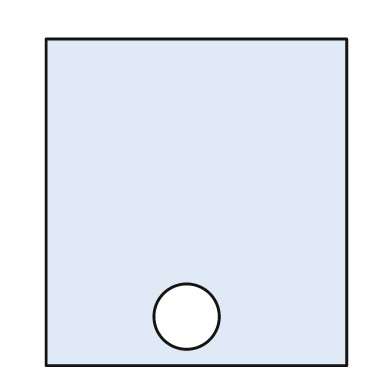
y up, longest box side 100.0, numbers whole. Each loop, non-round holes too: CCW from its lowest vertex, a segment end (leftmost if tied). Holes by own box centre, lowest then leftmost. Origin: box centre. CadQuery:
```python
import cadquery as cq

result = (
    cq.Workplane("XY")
    .moveTo(-46.0, -50.0)
    .lineTo(46.0, -50.0)
    .lineTo(46.0, 50.0)
    .lineTo(-46.0, 50.0)
    .close()
    .moveTo(-3.0, -35.0)
    .circle(10.0)
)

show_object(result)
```